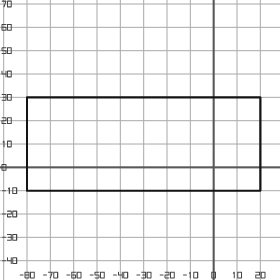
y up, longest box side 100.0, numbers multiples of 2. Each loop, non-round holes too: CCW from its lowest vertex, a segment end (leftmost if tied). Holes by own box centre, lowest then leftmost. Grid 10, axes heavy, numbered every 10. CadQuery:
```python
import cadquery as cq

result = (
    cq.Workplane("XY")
    .moveTo(-80.0, -10.0)
    .lineTo(20.0, -10.0)
    .lineTo(20.0, 30.0)
    .lineTo(-80.0, 30.0)
    .close()
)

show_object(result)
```